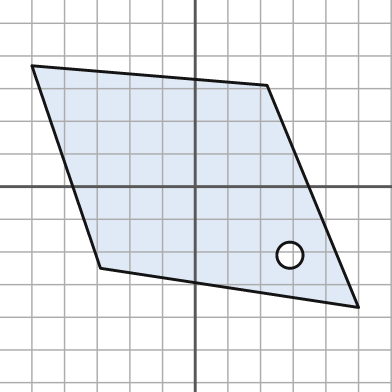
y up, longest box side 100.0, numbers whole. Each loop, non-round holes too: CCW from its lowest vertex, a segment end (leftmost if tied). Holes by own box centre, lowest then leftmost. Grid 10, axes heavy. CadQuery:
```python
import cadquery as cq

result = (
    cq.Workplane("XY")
    .moveTo(50.0, -37.0)
    .lineTo(22.0, 31.0)
    .lineTo(-50.0, 37.0)
    .lineTo(-29.0, -25.0)
    .close()
    .moveTo(29.0, -21.0)
    .circle(4.0)
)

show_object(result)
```